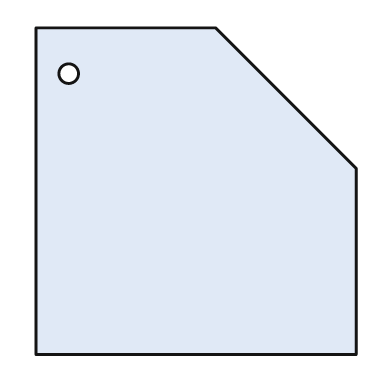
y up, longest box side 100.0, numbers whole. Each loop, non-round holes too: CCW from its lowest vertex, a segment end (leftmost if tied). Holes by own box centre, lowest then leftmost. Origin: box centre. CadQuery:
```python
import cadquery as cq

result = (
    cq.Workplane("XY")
    .moveTo(-49.0, -50.0)
    .lineTo(49.0, -50.0)
    .lineTo(49.0, 7.0)
    .lineTo(6.0, 50.0)
    .lineTo(-49.0, 50.0)
    .close()
    .moveTo(-39.0, 36.0)
    .circle(3.0)
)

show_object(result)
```